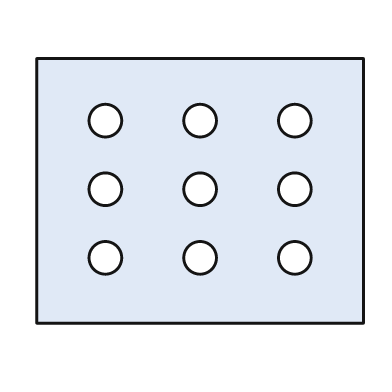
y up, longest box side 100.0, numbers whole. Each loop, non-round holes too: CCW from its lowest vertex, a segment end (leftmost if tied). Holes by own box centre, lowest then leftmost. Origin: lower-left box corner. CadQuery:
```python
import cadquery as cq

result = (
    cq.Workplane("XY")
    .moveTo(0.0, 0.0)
    .lineTo(100.0, 0.0)
    .lineTo(100.0, 81.0)
    .lineTo(0.0, 81.0)
    .close()
    .moveTo(21.0, 20.0)
    .circle(5.0)
    .moveTo(50.0, 20.0)
    .circle(5.0)
    .moveTo(79.0, 20.0)
    .circle(5.0)
    .moveTo(21.0, 41.0)
    .circle(5.0)
    .moveTo(50.0, 41.0)
    .circle(5.0)
    .moveTo(79.0, 41.0)
    .circle(5.0)
    .moveTo(21.0, 62.0)
    .circle(5.0)
    .moveTo(50.0, 62.0)
    .circle(5.0)
    .moveTo(79.0, 62.0)
    .circle(5.0)
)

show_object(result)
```